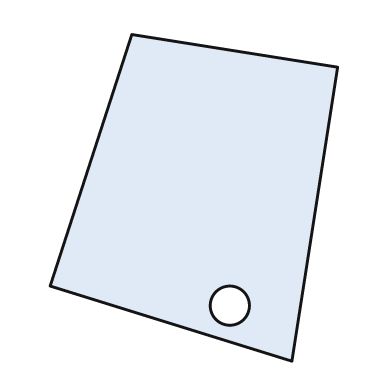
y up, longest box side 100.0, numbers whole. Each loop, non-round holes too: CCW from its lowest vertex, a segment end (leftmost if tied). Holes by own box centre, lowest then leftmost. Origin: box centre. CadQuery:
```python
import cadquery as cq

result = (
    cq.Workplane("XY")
    .moveTo(30.0, -50.0)
    .lineTo(44.0, 40.0)
    .lineTo(-19.0, 50.0)
    .lineTo(-44.0, -27.0)
    .close()
    .moveTo(11.0, -33.0)
    .circle(6.0)
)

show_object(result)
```